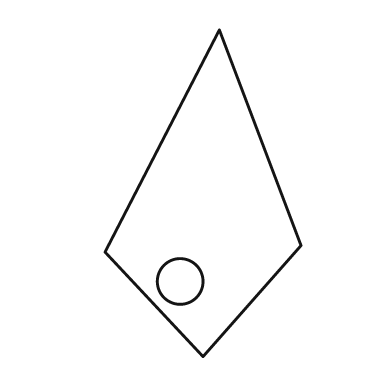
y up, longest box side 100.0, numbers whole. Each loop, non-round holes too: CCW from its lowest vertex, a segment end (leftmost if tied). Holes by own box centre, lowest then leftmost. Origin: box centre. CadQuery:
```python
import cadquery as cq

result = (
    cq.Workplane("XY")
    .moveTo(0.0, -50.0)
    .lineTo(30.0, -16.0)
    .lineTo(5.0, 50.0)
    .lineTo(-30.0, -18.0)
    .close()
    .moveTo(-7.0, -27.0)
    .circle(7.0)
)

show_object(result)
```